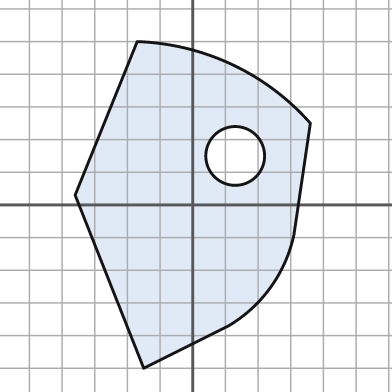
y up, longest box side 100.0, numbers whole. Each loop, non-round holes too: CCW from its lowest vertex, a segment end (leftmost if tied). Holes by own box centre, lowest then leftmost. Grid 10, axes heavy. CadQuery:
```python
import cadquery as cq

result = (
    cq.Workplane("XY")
    .moveTo(-15.0, -50.0)
    .lineTo(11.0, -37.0)
    .threePointArc((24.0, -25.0), (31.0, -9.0))
    .lineTo(36.0, 25.0)
    .threePointArc((12.0, 43.0), (-17.0, 50.0))
    .lineTo(-36.0, 3.0)
    .close()
    .moveTo(13.0, 15.0)
    .circle(9.0)
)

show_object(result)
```